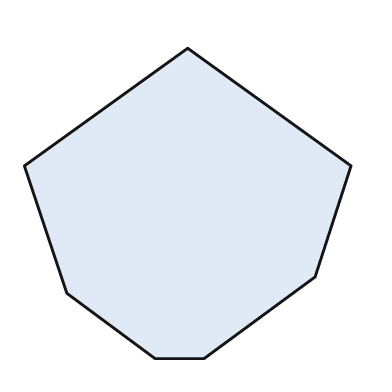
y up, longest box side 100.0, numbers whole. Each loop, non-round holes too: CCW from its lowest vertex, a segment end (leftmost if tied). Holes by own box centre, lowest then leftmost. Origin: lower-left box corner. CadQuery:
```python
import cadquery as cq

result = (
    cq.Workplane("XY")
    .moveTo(40.0, 0.0)
    .lineTo(55.0, 0.0)
    .lineTo(89.0, 25.0)
    .lineTo(100.0, 59.0)
    .lineTo(50.0, 95.0)
    .lineTo(0.0, 59.0)
    .lineTo(13.0, 20.0)
    .close()
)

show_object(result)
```